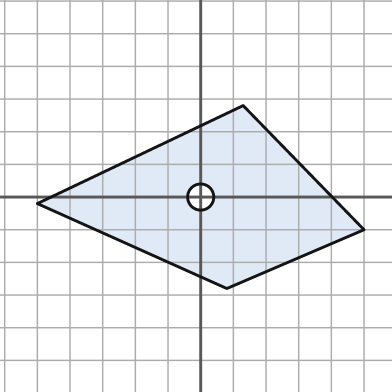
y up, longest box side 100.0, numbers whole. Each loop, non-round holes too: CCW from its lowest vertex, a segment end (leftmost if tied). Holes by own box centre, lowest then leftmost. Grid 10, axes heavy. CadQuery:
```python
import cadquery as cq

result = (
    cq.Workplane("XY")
    .moveTo(8.0, -28.0)
    .lineTo(50.0, -10.0)
    .lineTo(13.0, 28.0)
    .lineTo(-50.0, -2.0)
    .close()
    .moveTo(0.0, 0.0)
    .circle(4.0)
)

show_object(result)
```